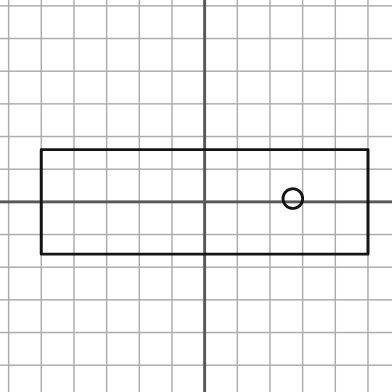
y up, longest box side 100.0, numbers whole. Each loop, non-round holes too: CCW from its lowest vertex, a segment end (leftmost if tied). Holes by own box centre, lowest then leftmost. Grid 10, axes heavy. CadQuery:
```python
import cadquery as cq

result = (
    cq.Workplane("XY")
    .moveTo(-50.0, -16.0)
    .lineTo(50.0, -16.0)
    .lineTo(50.0, 16.0)
    .lineTo(-50.0, 16.0)
    .close()
    .moveTo(27.0, 1.0)
    .circle(3.0)
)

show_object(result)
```